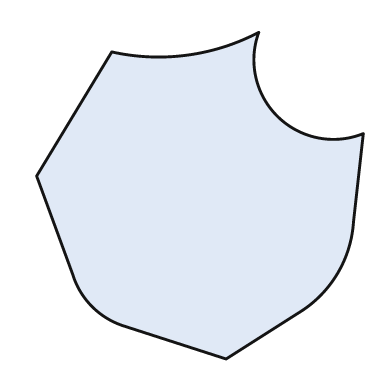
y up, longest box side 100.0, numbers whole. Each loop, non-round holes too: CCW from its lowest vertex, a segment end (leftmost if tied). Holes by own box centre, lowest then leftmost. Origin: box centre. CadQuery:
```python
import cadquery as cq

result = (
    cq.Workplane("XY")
    .moveTo(8.0, -50.0)
    .lineTo(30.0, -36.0)
    .threePointArc((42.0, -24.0), (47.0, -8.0))
    .lineTo(50.0, 19.0)
    .threePointArc((24.0, 24.0), (18.0, 50.0))
    .threePointArc((-4.0, 43.0), (-27.0, 44.0))
    .lineTo(-50.0, 6.0)
    .lineTo(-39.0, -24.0)
    .threePointArc((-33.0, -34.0), (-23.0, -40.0))
    .close()
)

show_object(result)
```